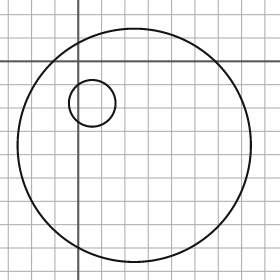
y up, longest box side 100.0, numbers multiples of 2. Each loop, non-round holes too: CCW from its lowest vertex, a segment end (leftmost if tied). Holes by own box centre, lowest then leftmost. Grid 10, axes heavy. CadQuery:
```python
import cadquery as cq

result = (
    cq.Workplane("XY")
    .moveTo(24.0, -36.0)
    .circle(50.0)
    .moveTo(6.0, -18.0)
    .circle(10.0)
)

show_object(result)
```